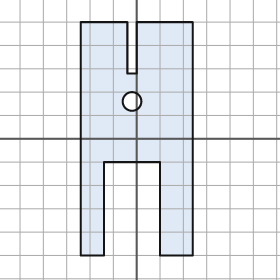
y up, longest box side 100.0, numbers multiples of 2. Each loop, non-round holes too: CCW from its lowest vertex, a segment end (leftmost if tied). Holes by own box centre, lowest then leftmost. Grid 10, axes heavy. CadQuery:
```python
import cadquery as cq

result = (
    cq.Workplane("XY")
    .moveTo(-24.0, -50.0)
    .lineTo(-14.0, -50.0)
    .lineTo(-14.0, -10.0)
    .lineTo(10.0, -10.0)
    .lineTo(10.0, -50.0)
    .lineTo(24.0, -50.0)
    .lineTo(24.0, 50.0)
    .lineTo(0.0, 50.0)
    .lineTo(0.0, 28.0)
    .lineTo(-4.0, 28.0)
    .lineTo(-4.0, 50.0)
    .lineTo(-24.0, 50.0)
    .close()
    .moveTo(-2.0, 16.0)
    .circle(4.0)
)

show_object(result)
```